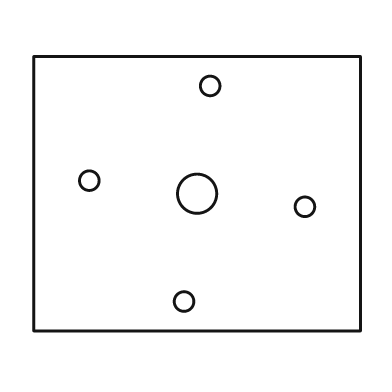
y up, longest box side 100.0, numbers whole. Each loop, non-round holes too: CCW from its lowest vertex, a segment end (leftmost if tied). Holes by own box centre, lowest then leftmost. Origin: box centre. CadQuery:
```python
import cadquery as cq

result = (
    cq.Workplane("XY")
    .moveTo(-50.0, -42.0)
    .lineTo(50.0, -42.0)
    .lineTo(50.0, 42.0)
    .lineTo(-50.0, 42.0)
    .close()
    .moveTo(-4.0, -33.0)
    .circle(3.0)
    .moveTo(33.0, -4.0)
    .circle(3.0)
    .moveTo(0.0, 0.0)
    .circle(6.0)
    .moveTo(-33.0, 4.0)
    .circle(3.0)
    .moveTo(4.0, 33.0)
    .circle(3.0)
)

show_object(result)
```